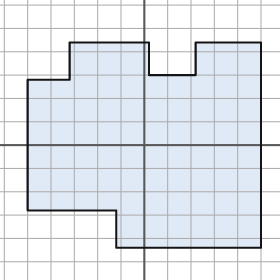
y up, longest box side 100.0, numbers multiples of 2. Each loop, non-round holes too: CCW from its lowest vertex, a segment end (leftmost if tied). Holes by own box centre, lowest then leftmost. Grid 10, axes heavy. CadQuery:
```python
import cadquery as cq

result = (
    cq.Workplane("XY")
    .moveTo(-12.0, -44.0)
    .lineTo(50.0, -44.0)
    .lineTo(50.0, 44.0)
    .lineTo(22.0, 44.0)
    .lineTo(22.0, 30.0)
    .lineTo(2.0, 30.0)
    .lineTo(2.0, 44.0)
    .lineTo(-32.0, 44.0)
    .lineTo(-32.0, 28.0)
    .lineTo(-50.0, 28.0)
    .lineTo(-50.0, -28.0)
    .lineTo(-12.0, -28.0)
    .close()
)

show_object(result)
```